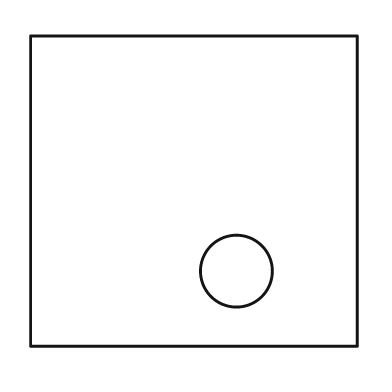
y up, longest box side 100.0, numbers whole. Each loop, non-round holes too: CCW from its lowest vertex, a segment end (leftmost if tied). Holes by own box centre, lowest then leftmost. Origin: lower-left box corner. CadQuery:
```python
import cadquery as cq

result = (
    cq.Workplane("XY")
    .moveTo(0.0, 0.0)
    .lineTo(100.0, 0.0)
    .lineTo(100.0, 95.0)
    .lineTo(0.0, 95.0)
    .close()
    .moveTo(63.0, 23.0)
    .circle(11.0)
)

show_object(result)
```